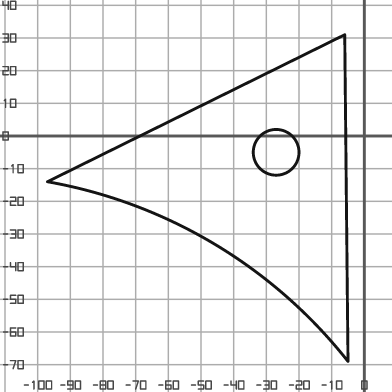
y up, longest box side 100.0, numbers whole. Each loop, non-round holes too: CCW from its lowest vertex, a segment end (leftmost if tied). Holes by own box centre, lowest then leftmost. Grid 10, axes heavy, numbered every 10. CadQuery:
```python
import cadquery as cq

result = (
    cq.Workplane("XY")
    .moveTo(-5.0, -69.0)
    .lineTo(-6.0, 31.0)
    .lineTo(-97.0, -14.0)
    .threePointArc((-46.0, -33.0), (-5.0, -69.0))
    .close()
    .moveTo(-27.0, -5.0)
    .circle(7.0)
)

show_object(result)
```